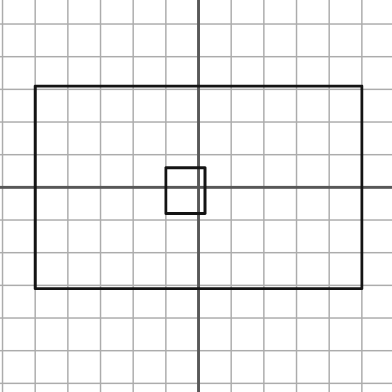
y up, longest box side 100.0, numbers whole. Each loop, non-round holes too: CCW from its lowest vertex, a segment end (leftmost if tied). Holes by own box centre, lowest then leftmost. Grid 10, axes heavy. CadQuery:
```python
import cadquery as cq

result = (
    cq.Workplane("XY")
    .moveTo(-50.0, -31.0)
    .lineTo(50.0, -31.0)
    .lineTo(50.0, 31.0)
    .lineTo(-50.0, 31.0)
    .close()
    .moveTo(-10.0, -8.0)
    .lineTo(2.0, -8.0)
    .lineTo(2.0, 6.0)
    .lineTo(-10.0, 6.0)
    .close()
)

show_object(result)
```